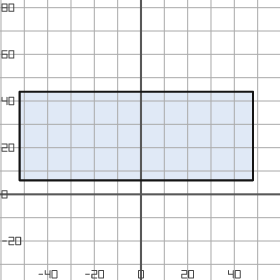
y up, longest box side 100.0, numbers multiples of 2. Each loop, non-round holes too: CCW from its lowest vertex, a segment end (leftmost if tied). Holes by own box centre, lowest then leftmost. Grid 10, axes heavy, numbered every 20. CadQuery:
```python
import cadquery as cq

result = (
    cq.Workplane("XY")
    .moveTo(-52.0, 6.0)
    .lineTo(48.0, 6.0)
    .lineTo(48.0, 44.0)
    .lineTo(-52.0, 44.0)
    .close()
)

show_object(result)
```